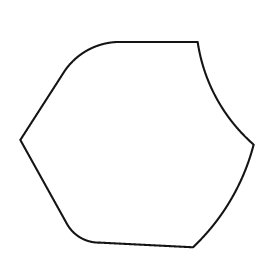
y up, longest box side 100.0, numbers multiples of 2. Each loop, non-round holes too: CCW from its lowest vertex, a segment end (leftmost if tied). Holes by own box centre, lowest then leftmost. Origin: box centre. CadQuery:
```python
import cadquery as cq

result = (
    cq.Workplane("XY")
    .moveTo(24.0, -44.0)
    .threePointArc((40.0, -24.0), (50.0, 0.0))
    .threePointArc((34.0, 20.0), (26.0, 44.0))
    .lineTo(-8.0, 44.0)
    .threePointArc((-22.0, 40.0), (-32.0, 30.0))
    .lineTo(-50.0, 2.0)
    .lineTo(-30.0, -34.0)
    .threePointArc((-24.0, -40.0), (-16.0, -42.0))
    .close()
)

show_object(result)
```